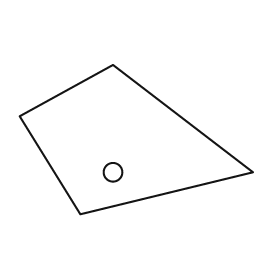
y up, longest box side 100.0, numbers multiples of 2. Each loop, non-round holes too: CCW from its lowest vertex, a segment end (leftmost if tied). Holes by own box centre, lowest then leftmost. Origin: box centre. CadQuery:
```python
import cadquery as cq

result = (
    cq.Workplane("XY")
    .moveTo(-24.0, -32.0)
    .lineTo(50.0, -14.0)
    .lineTo(-10.0, 32.0)
    .lineTo(-50.0, 10.0)
    .close()
    .moveTo(-10.0, -14.0)
    .circle(4.0)
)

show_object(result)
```